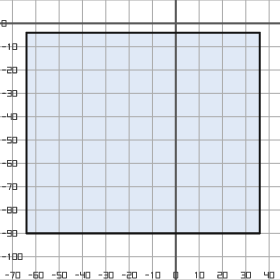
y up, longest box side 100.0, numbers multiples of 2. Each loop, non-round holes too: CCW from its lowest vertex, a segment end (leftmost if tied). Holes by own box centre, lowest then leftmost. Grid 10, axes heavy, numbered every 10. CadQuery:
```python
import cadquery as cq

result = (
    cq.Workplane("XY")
    .moveTo(-64.0, -90.0)
    .lineTo(36.0, -90.0)
    .lineTo(36.0, -4.0)
    .lineTo(-64.0, -4.0)
    .close()
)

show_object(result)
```